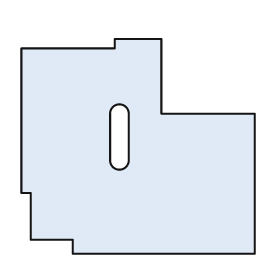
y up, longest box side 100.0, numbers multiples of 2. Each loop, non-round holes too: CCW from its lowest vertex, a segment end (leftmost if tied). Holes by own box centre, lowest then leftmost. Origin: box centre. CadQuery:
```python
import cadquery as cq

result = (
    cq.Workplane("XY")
    .moveTo(-28.0, -46.0)
    .lineTo(50.0, -46.0)
    .lineTo(50.0, 14.0)
    .lineTo(10.0, 14.0)
    .lineTo(10.0, 46.0)
    .lineTo(-10.0, 46.0)
    .lineTo(-10.0, 42.0)
    .lineTo(-50.0, 42.0)
    .lineTo(-50.0, -20.0)
    .lineTo(-46.0, -20.0)
    .lineTo(-46.0, -40.0)
    .lineTo(-28.0, -40.0)
    .close()
    .moveTo(-12.0, -6.0)
    .threePointArc((-8.0, -10.0), (-4.0, -6.0))
    .lineTo(-4.0, 14.0)
    .threePointArc((-8.0, 18.0), (-12.0, 14.0))
    .close()
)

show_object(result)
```